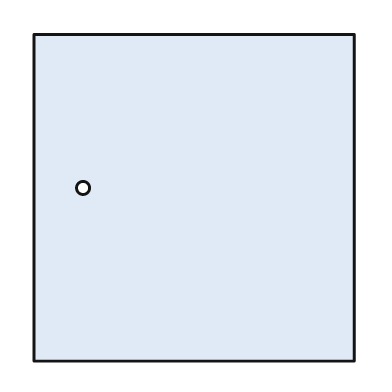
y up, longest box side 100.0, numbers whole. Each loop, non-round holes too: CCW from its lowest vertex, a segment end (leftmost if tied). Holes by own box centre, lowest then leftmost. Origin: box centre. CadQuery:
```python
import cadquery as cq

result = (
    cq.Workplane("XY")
    .moveTo(-49.0, -50.0)
    .lineTo(49.0, -50.0)
    .lineTo(49.0, 50.0)
    .lineTo(-49.0, 50.0)
    .close()
    .moveTo(-34.0, 3.0)
    .circle(2.0)
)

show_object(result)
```